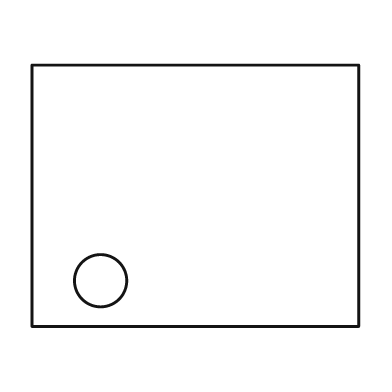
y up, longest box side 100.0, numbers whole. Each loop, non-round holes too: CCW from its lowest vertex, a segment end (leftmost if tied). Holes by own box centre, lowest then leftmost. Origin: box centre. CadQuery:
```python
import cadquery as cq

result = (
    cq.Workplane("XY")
    .moveTo(-50.0, -40.0)
    .lineTo(50.0, -40.0)
    .lineTo(50.0, 40.0)
    .lineTo(-50.0, 40.0)
    .close()
    .moveTo(-29.0, -26.0)
    .circle(8.0)
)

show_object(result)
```